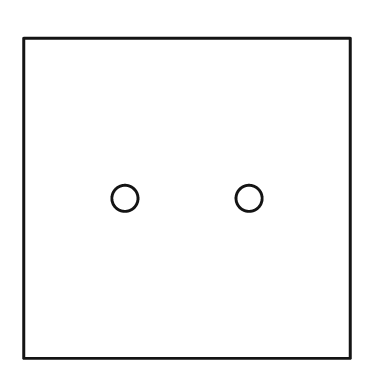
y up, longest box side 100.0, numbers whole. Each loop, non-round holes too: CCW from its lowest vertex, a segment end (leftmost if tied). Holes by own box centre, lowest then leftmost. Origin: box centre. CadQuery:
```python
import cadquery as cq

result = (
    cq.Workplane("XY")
    .moveTo(-50.0, -49.0)
    .lineTo(50.0, -49.0)
    .lineTo(50.0, 49.0)
    .lineTo(-50.0, 49.0)
    .close()
    .moveTo(-19.0, 0.0)
    .circle(4.0)
    .moveTo(19.0, 0.0)
    .circle(4.0)
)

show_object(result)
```